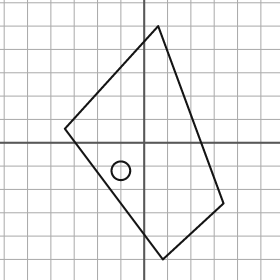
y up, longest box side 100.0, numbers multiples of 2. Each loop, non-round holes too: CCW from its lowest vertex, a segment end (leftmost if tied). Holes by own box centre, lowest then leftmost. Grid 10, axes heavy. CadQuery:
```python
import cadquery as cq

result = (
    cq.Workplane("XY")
    .moveTo(8.0, -50.0)
    .lineTo(34.0, -26.0)
    .lineTo(6.0, 50.0)
    .lineTo(-34.0, 6.0)
    .close()
    .moveTo(-10.0, -12.0)
    .circle(4.0)
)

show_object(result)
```